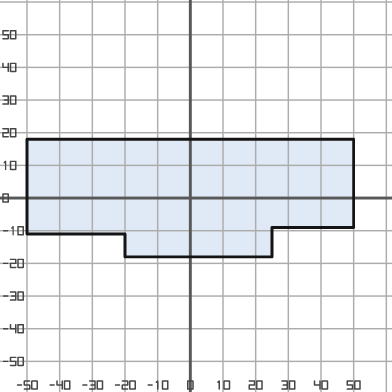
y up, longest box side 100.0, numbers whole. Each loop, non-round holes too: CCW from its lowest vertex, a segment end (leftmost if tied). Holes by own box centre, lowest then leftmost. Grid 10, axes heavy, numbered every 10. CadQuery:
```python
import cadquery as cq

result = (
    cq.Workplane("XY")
    .moveTo(-20.0, -18.0)
    .lineTo(25.0, -18.0)
    .lineTo(25.0, -9.0)
    .lineTo(50.0, -9.0)
    .lineTo(50.0, 18.0)
    .lineTo(-50.0, 18.0)
    .lineTo(-50.0, -11.0)
    .lineTo(-20.0, -11.0)
    .close()
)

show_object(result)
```